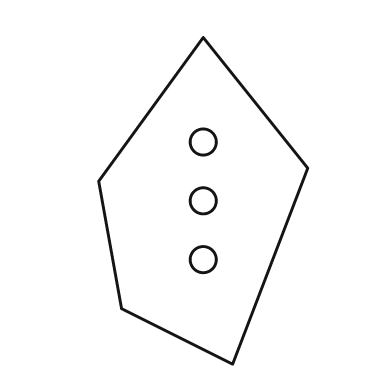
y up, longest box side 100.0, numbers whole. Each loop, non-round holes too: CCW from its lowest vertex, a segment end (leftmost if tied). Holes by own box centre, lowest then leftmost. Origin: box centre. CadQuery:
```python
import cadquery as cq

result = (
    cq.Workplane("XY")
    .moveTo(9.0, -50.0)
    .lineTo(32.0, 10.0)
    .lineTo(0.0, 50.0)
    .lineTo(-32.0, 6.0)
    .lineTo(-25.0, -33.0)
    .close()
    .moveTo(0.0, -18.0)
    .circle(4.0)
    .moveTo(0.0, 0.0)
    .circle(4.0)
    .moveTo(0.0, 18.0)
    .circle(4.0)
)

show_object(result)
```